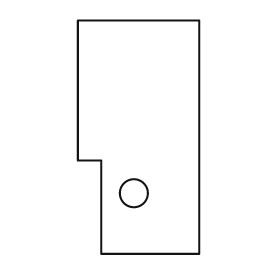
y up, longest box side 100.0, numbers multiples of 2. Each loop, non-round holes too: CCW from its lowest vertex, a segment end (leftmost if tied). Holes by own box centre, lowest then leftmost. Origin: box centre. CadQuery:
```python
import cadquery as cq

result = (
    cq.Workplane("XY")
    .moveTo(-16.0, -50.0)
    .lineTo(26.0, -50.0)
    .lineTo(26.0, 50.0)
    .lineTo(-26.0, 50.0)
    .lineTo(-26.0, -10.0)
    .lineTo(-16.0, -10.0)
    .close()
    .moveTo(-2.0, -24.0)
    .circle(6.0)
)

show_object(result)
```